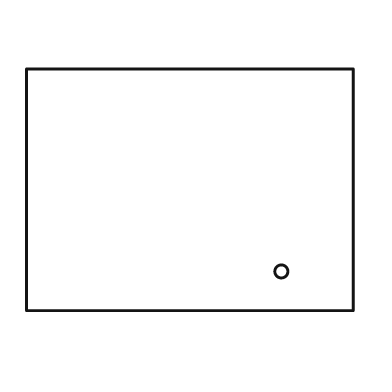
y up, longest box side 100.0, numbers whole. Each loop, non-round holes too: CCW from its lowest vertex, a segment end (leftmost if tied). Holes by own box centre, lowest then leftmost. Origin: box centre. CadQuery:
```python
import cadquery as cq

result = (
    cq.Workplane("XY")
    .moveTo(-50.0, -37.0)
    .lineTo(50.0, -37.0)
    .lineTo(50.0, 37.0)
    .lineTo(-50.0, 37.0)
    .close()
    .moveTo(28.0, -25.0)
    .circle(2.0)
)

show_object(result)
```